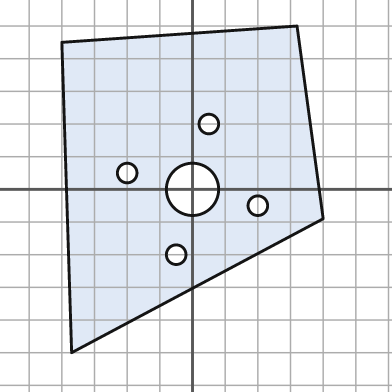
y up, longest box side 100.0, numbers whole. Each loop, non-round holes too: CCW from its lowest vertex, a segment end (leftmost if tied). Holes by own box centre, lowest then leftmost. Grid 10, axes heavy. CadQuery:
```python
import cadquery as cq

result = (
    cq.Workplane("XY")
    .moveTo(-37.0, -50.0)
    .lineTo(40.0, -9.0)
    .lineTo(32.0, 50.0)
    .lineTo(-40.0, 45.0)
    .close()
    .moveTo(-5.0, -20.0)
    .circle(3.0)
    .moveTo(20.0, -5.0)
    .circle(3.0)
    .moveTo(0.0, 0.0)
    .circle(8.0)
    .moveTo(-20.0, 5.0)
    .circle(3.0)
    .moveTo(5.0, 20.0)
    .circle(3.0)
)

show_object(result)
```